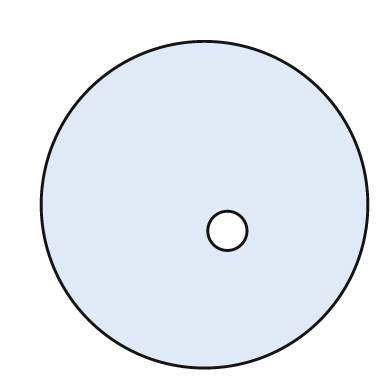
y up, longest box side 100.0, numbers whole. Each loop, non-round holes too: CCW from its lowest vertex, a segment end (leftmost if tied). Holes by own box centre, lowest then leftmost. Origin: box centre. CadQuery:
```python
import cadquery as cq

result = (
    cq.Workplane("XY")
    .moveTo(0.0, 0.0)
    .circle(50.0)
    .moveTo(7.0, -8.0)
    .circle(6.0)
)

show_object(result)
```